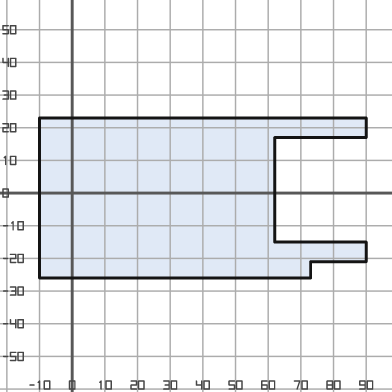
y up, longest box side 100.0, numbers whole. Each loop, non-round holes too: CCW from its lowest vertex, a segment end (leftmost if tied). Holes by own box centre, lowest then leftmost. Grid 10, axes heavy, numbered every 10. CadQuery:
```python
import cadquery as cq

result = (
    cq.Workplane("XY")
    .moveTo(-10.0, -26.0)
    .lineTo(73.0, -26.0)
    .lineTo(73.0, -21.0)
    .lineTo(90.0, -21.0)
    .lineTo(90.0, -15.0)
    .lineTo(62.0, -15.0)
    .lineTo(62.0, 17.0)
    .lineTo(90.0, 17.0)
    .lineTo(90.0, 23.0)
    .lineTo(-10.0, 23.0)
    .close()
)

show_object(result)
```